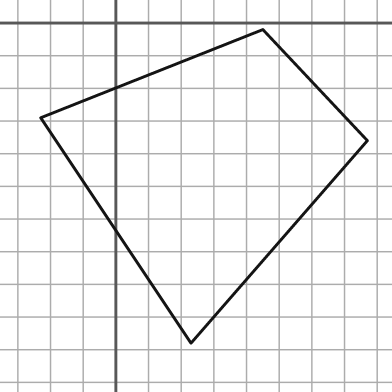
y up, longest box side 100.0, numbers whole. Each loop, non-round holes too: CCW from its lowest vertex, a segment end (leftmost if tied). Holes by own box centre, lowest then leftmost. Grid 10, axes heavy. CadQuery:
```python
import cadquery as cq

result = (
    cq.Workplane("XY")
    .moveTo(23.0, -98.0)
    .lineTo(77.0, -36.0)
    .lineTo(45.0, -2.0)
    .lineTo(-23.0, -29.0)
    .close()
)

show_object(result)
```